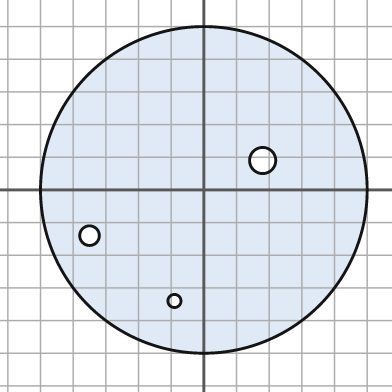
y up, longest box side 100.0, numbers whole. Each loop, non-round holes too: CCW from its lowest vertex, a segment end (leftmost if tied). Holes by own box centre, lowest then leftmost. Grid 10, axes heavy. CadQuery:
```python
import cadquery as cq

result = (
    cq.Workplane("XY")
    .moveTo(0.0, 0.0)
    .circle(50.0)
    .moveTo(-9.0, -34.0)
    .circle(2.0)
    .moveTo(-35.0, -14.0)
    .circle(3.0)
    .moveTo(18.0, 9.0)
    .circle(4.0)
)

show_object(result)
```